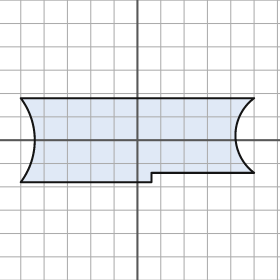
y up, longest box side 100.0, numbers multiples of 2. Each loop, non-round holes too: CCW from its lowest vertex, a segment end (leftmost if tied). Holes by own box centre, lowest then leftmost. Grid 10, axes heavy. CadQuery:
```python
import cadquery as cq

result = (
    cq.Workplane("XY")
    .moveTo(-50.0, -18.0)
    .lineTo(6.0, -18.0)
    .lineTo(6.0, -14.0)
    .lineTo(50.0, -14.0)
    .threePointArc((42.0, 2.0), (50.0, 18.0))
    .lineTo(-50.0, 18.0)
    .threePointArc((-44.0, 0.0), (-50.0, -18.0))
    .close()
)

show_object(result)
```